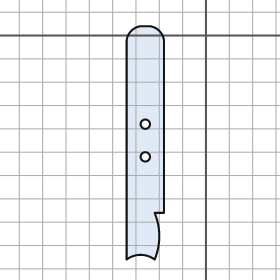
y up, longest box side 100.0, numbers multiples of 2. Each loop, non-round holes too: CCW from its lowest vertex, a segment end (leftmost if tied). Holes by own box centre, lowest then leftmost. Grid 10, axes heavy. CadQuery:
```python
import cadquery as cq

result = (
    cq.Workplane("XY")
    .moveTo(-34.0, -96.0)
    .threePointArc((-28.0, -94.0), (-22.0, -96.0))
    .threePointArc((-20.0, -86.0), (-22.0, -76.0))
    .lineTo(-18.0, -76.0)
    .lineTo(-18.0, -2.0)
    .threePointArc((-20.0, 2.0), (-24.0, 4.0))
    .lineTo(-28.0, 4.0)
    .threePointArc((-32.0, 2.0), (-34.0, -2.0))
    .close()
    .moveTo(-26.0, -52.0)
    .circle(2.0)
    .moveTo(-26.0, -38.0)
    .circle(2.0)
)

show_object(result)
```